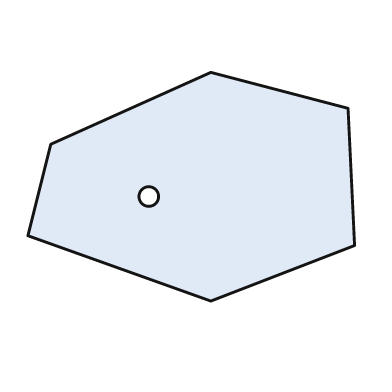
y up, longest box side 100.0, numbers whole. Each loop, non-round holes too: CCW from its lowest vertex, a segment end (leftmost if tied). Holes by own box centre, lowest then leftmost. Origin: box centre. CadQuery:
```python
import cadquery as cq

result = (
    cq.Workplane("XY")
    .moveTo(6.0, -35.0)
    .lineTo(50.0, -18.0)
    .lineTo(48.0, 24.0)
    .lineTo(6.0, 35.0)
    .lineTo(-43.0, 13.0)
    .lineTo(-50.0, -15.0)
    .close()
    .moveTo(-13.0, -3.0)
    .circle(3.0)
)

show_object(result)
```